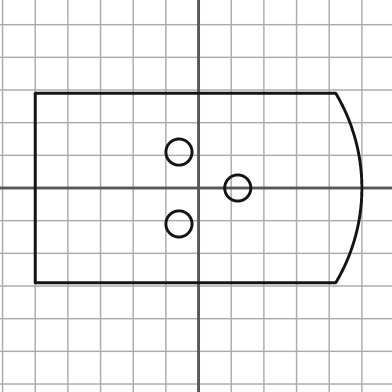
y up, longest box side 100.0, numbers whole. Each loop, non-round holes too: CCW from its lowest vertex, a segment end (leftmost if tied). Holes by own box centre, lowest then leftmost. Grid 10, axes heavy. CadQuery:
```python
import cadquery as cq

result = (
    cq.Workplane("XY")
    .moveTo(-50.0, -29.0)
    .lineTo(42.0, -29.0)
    .threePointArc((50.0, 0.0), (42.0, 29.0))
    .lineTo(-50.0, 29.0)
    .close()
    .moveTo(-6.0, -11.0)
    .circle(4.0)
    .moveTo(12.0, 0.0)
    .circle(4.0)
    .moveTo(-6.0, 11.0)
    .circle(4.0)
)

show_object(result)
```